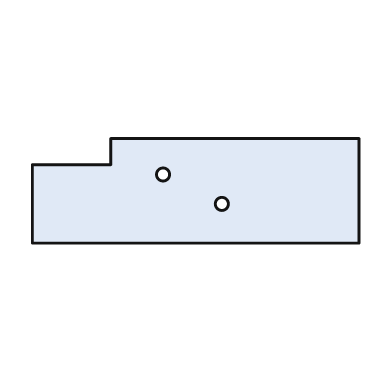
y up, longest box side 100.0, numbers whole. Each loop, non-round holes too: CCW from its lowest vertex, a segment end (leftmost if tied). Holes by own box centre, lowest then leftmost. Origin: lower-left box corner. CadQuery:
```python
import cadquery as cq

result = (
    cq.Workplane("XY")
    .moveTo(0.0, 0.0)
    .lineTo(100.0, 0.0)
    .lineTo(100.0, 32.0)
    .lineTo(24.0, 32.0)
    .lineTo(24.0, 24.0)
    .lineTo(0.0, 24.0)
    .close()
    .moveTo(58.0, 12.0)
    .circle(2.0)
    .moveTo(40.0, 21.0)
    .circle(2.0)
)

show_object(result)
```